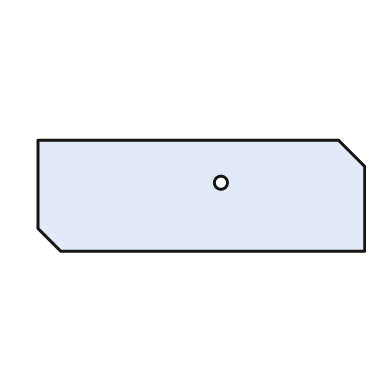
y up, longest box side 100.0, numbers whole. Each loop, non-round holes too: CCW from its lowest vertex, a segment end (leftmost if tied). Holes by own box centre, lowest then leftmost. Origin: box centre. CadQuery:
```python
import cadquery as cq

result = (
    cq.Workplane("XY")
    .moveTo(-43.0, -17.0)
    .lineTo(50.0, -17.0)
    .lineTo(50.0, 9.0)
    .lineTo(42.0, 17.0)
    .lineTo(-50.0, 17.0)
    .lineTo(-50.0, -10.0)
    .close()
    .moveTo(6.0, 4.0)
    .circle(2.0)
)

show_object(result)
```